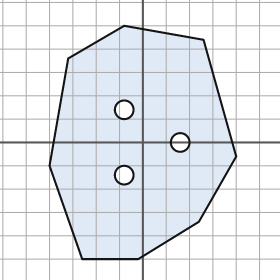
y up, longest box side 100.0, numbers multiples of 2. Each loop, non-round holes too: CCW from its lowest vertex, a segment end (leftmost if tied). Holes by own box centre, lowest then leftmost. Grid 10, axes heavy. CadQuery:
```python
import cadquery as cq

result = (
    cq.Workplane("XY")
    .moveTo(-26.0, -50.0)
    .lineTo(-2.0, -50.0)
    .lineTo(24.0, -34.0)
    .lineTo(40.0, -6.0)
    .lineTo(26.0, 44.0)
    .lineTo(-8.0, 50.0)
    .lineTo(-32.0, 36.0)
    .lineTo(-40.0, -10.0)
    .close()
    .moveTo(-8.0, -14.0)
    .circle(4.0)
    .moveTo(16.0, 0.0)
    .circle(4.0)
    .moveTo(-8.0, 14.0)
    .circle(4.0)
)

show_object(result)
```